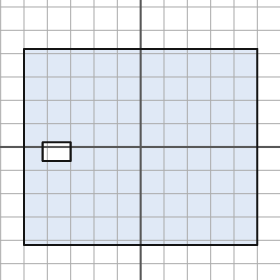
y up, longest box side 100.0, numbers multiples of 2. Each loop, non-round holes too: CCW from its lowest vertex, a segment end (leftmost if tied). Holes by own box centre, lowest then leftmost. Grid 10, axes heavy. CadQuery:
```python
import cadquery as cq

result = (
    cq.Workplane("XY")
    .moveTo(-50.0, -42.0)
    .lineTo(50.0, -42.0)
    .lineTo(50.0, 42.0)
    .lineTo(-50.0, 42.0)
    .close()
    .moveTo(-42.0, -6.0)
    .lineTo(-30.0, -6.0)
    .lineTo(-30.0, 2.0)
    .lineTo(-42.0, 2.0)
    .close()
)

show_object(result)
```